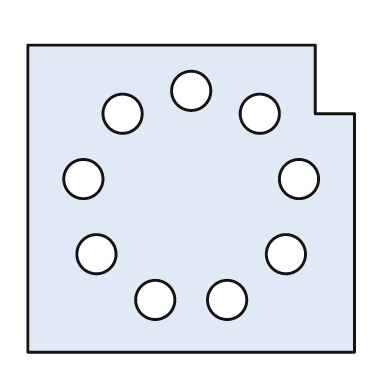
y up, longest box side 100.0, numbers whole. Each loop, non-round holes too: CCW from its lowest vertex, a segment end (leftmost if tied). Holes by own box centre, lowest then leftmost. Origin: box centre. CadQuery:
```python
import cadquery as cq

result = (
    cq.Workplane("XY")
    .moveTo(-50.0, -47.0)
    .lineTo(50.0, -47.0)
    .lineTo(50.0, 26.0)
    .lineTo(38.0, 26.0)
    .lineTo(38.0, 47.0)
    .lineTo(-50.0, 47.0)
    .close()
    .moveTo(-11.0, -31.0)
    .circle(6.0)
    .moveTo(11.0, -31.0)
    .circle(6.0)
    .moveTo(-29.0, -17.0)
    .circle(6.0)
    .moveTo(29.0, -17.0)
    .circle(6.0)
    .moveTo(-33.0, 6.0)
    .circle(6.0)
    .moveTo(33.0, 6.0)
    .circle(6.0)
    .moveTo(-21.0, 26.0)
    .circle(6.0)
    .moveTo(21.0, 26.0)
    .circle(6.0)
    .moveTo(0.0, 33.0)
    .circle(6.0)
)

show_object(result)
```